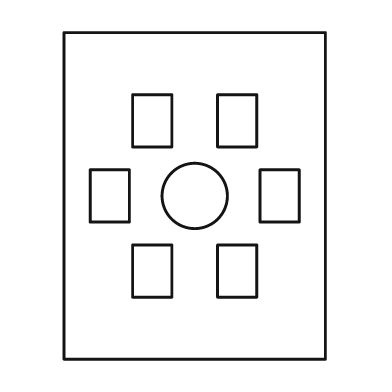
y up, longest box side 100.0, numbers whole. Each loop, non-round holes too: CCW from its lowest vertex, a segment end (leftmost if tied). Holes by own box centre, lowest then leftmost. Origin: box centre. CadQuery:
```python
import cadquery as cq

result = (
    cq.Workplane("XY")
    .moveTo(-40.0, -50.0)
    .lineTo(40.0, -50.0)
    .lineTo(40.0, 50.0)
    .lineTo(-40.0, 50.0)
    .close()
    .moveTo(-19.0, -31.0)
    .lineTo(-7.0, -31.0)
    .lineTo(-7.0, -15.0)
    .lineTo(-19.0, -15.0)
    .close()
    .moveTo(7.0, -31.0)
    .lineTo(19.0, -31.0)
    .lineTo(19.0, -15.0)
    .lineTo(7.0, -15.0)
    .close()
    .moveTo(-32.0, -8.0)
    .lineTo(-20.0, -8.0)
    .lineTo(-20.0, 8.0)
    .lineTo(-32.0, 8.0)
    .close()
    .moveTo(0.0, 0.0)
    .circle(10.0)
    .moveTo(20.0, -8.0)
    .lineTo(32.0, -8.0)
    .lineTo(32.0, 8.0)
    .lineTo(20.0, 8.0)
    .close()
    .moveTo(-19.0, 15.0)
    .lineTo(-7.0, 15.0)
    .lineTo(-7.0, 31.0)
    .lineTo(-19.0, 31.0)
    .close()
    .moveTo(7.0, 15.0)
    .lineTo(19.0, 15.0)
    .lineTo(19.0, 31.0)
    .lineTo(7.0, 31.0)
    .close()
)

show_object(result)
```